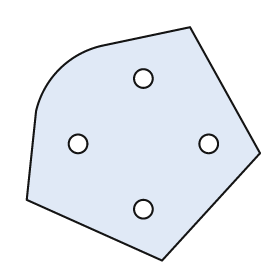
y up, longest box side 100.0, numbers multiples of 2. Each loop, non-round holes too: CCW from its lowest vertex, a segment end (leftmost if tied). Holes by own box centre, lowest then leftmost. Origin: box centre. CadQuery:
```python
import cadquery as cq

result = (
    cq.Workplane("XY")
    .moveTo(8.0, -50.0)
    .lineTo(50.0, -4.0)
    .lineTo(20.0, 50.0)
    .lineTo(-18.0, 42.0)
    .threePointArc((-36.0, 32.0), (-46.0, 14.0))
    .lineTo(-50.0, -24.0)
    .close()
    .moveTo(0.0, -28.0)
    .circle(4.0)
    .moveTo(-28.0, 0.0)
    .circle(4.0)
    .moveTo(28.0, 0.0)
    .circle(4.0)
    .moveTo(0.0, 28.0)
    .circle(4.0)
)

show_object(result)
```